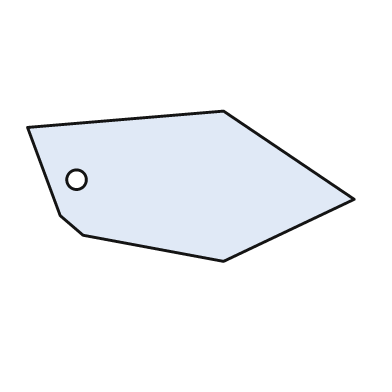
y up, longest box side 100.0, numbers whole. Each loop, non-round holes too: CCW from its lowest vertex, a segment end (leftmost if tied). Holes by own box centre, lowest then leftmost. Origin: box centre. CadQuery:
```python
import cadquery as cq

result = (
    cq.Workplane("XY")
    .moveTo(10.0, -23.0)
    .lineTo(50.0, -4.0)
    .lineTo(10.0, 23.0)
    .lineTo(-50.0, 18.0)
    .lineTo(-40.0, -9.0)
    .lineTo(-33.0, -15.0)
    .close()
    .moveTo(-35.0, 2.0)
    .circle(3.0)
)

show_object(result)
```